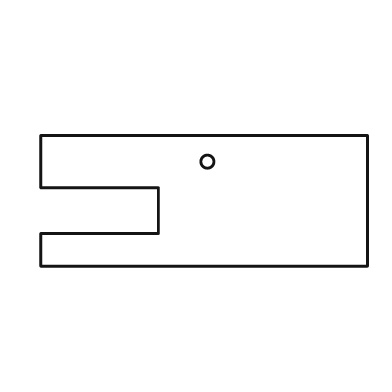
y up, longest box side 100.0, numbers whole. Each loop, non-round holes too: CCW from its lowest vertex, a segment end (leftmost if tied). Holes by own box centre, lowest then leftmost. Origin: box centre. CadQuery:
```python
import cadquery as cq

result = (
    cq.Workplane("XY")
    .moveTo(-50.0, -20.0)
    .lineTo(50.0, -20.0)
    .lineTo(50.0, 20.0)
    .lineTo(-50.0, 20.0)
    .lineTo(-50.0, 4.0)
    .lineTo(-14.0, 4.0)
    .lineTo(-14.0, -10.0)
    .lineTo(-50.0, -10.0)
    .close()
    .moveTo(1.0, 12.0)
    .circle(2.0)
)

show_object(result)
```